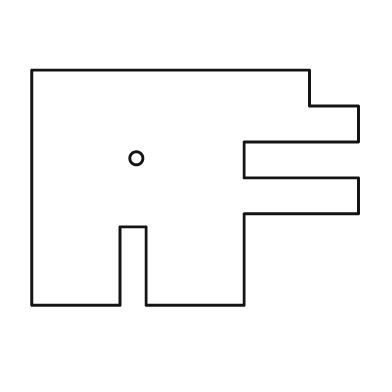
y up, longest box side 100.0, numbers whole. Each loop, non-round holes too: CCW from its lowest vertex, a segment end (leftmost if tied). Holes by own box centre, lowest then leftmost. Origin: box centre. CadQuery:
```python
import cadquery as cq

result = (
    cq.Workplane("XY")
    .moveTo(-50.0, -36.0)
    .lineTo(-23.0, -36.0)
    .lineTo(-23.0, -12.0)
    .lineTo(-15.0, -12.0)
    .lineTo(-15.0, -36.0)
    .lineTo(15.0, -36.0)
    .lineTo(15.0, -8.0)
    .lineTo(50.0, -8.0)
    .lineTo(50.0, 3.0)
    .lineTo(15.0, 3.0)
    .lineTo(15.0, 14.0)
    .lineTo(50.0, 14.0)
    .lineTo(50.0, 25.0)
    .lineTo(35.0, 25.0)
    .lineTo(35.0, 36.0)
    .lineTo(-50.0, 36.0)
    .close()
    .moveTo(-18.0, 9.0)
    .circle(2.0)
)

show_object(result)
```